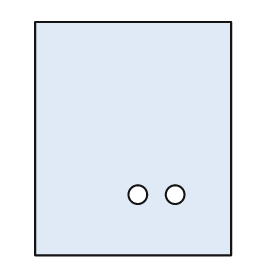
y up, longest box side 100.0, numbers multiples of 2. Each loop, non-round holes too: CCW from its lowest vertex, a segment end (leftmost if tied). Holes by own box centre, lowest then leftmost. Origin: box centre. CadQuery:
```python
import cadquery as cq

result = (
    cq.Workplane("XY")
    .moveTo(-42.0, -50.0)
    .lineTo(42.0, -50.0)
    .lineTo(42.0, 50.0)
    .lineTo(-42.0, 50.0)
    .close()
    .moveTo(2.0, -24.0)
    .circle(4.0)
    .moveTo(18.0, -24.0)
    .circle(4.0)
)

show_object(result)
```